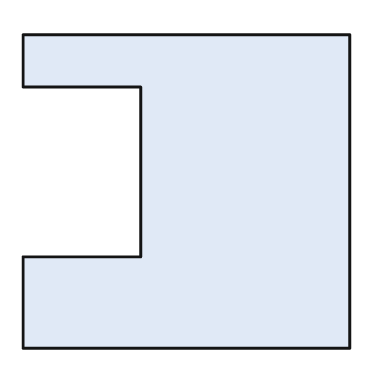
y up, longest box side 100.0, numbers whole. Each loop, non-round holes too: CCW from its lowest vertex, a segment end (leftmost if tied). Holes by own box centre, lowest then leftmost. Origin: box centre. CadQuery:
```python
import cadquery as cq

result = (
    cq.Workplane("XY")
    .moveTo(-50.0, -48.0)
    .lineTo(50.0, -48.0)
    .lineTo(50.0, 48.0)
    .lineTo(-50.0, 48.0)
    .lineTo(-50.0, 32.0)
    .lineTo(-14.0, 32.0)
    .lineTo(-14.0, -20.0)
    .lineTo(-50.0, -20.0)
    .close()
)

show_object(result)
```